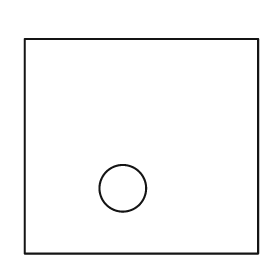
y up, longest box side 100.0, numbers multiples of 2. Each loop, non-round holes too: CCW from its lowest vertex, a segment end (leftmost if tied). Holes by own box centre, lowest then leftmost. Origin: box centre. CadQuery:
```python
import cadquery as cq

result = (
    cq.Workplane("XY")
    .moveTo(-50.0, -46.0)
    .lineTo(50.0, -46.0)
    .lineTo(50.0, 46.0)
    .lineTo(-50.0, 46.0)
    .close()
    .moveTo(-8.0, -18.0)
    .circle(10.0)
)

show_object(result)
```